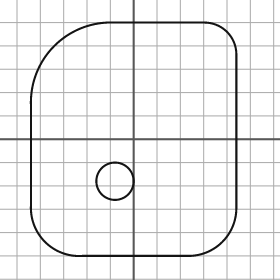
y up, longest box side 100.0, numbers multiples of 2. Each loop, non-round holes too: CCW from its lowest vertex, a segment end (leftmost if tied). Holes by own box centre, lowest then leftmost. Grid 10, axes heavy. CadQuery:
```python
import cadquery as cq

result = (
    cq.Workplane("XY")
    .moveTo(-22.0, -50.0)
    .lineTo(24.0, -50.0)
    .threePointArc((38.0, -44.0), (44.0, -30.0))
    .lineTo(44.0, 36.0)
    .threePointArc((40.0, 46.0), (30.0, 50.0))
    .lineTo(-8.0, 50.0)
    .threePointArc((-34.0, 40.0), (-44.0, 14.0))
    .lineTo(-44.0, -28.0)
    .threePointArc((-38.0, -44.0), (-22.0, -50.0))
    .close()
    .moveTo(-8.0, -18.0)
    .circle(8.0)
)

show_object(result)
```